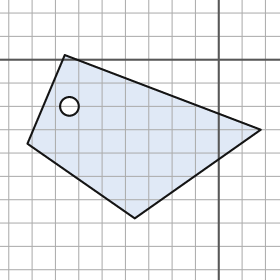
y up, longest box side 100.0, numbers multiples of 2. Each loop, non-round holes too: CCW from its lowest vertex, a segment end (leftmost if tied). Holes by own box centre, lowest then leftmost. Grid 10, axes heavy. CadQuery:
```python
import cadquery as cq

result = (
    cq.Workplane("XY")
    .moveTo(-36.0, -68.0)
    .lineTo(18.0, -30.0)
    .lineTo(-66.0, 2.0)
    .lineTo(-82.0, -36.0)
    .close()
    .moveTo(-64.0, -20.0)
    .circle(4.0)
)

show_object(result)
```